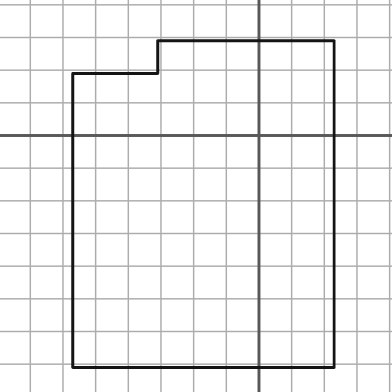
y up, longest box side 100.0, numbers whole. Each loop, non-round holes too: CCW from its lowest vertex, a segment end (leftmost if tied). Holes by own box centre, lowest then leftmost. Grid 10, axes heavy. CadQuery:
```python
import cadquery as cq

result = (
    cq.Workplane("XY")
    .moveTo(-57.0, -71.0)
    .lineTo(23.0, -71.0)
    .lineTo(23.0, 29.0)
    .lineTo(-31.0, 29.0)
    .lineTo(-31.0, 19.0)
    .lineTo(-57.0, 19.0)
    .close()
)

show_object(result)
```